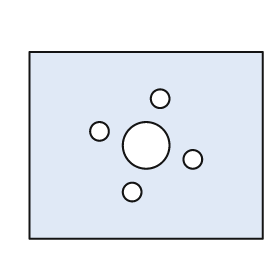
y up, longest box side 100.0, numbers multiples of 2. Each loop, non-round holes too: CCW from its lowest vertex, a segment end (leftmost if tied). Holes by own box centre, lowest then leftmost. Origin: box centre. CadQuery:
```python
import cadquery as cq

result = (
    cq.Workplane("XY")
    .moveTo(-50.0, -40.0)
    .lineTo(50.0, -40.0)
    .lineTo(50.0, 40.0)
    .lineTo(-50.0, 40.0)
    .close()
    .moveTo(-6.0, -20.0)
    .circle(4.0)
    .moveTo(20.0, -6.0)
    .circle(4.0)
    .moveTo(0.0, 0.0)
    .circle(10.0)
    .moveTo(-20.0, 6.0)
    .circle(4.0)
    .moveTo(6.0, 20.0)
    .circle(4.0)
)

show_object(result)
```